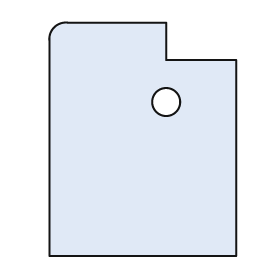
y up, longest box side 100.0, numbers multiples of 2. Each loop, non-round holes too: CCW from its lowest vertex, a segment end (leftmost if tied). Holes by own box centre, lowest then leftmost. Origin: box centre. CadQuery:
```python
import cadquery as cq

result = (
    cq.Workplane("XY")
    .moveTo(-40.0, -50.0)
    .lineTo(40.0, -50.0)
    .lineTo(40.0, 34.0)
    .lineTo(10.0, 34.0)
    .lineTo(10.0, 50.0)
    .lineTo(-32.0, 50.0)
    .threePointArc((-38.0, 48.0), (-40.0, 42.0))
    .close()
    .moveTo(10.0, 16.0)
    .circle(6.0)
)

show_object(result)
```